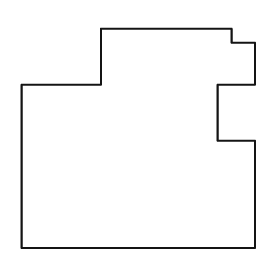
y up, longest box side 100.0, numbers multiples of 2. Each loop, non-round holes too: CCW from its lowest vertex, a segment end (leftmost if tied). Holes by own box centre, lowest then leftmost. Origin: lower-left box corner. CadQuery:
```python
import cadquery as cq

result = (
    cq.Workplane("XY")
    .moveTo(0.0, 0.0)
    .lineTo(100.0, 0.0)
    .lineTo(100.0, 46.0)
    .lineTo(84.0, 46.0)
    .lineTo(84.0, 70.0)
    .lineTo(100.0, 70.0)
    .lineTo(100.0, 88.0)
    .lineTo(90.0, 88.0)
    .lineTo(90.0, 94.0)
    .lineTo(34.0, 94.0)
    .lineTo(34.0, 70.0)
    .lineTo(0.0, 70.0)
    .close()
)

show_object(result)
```